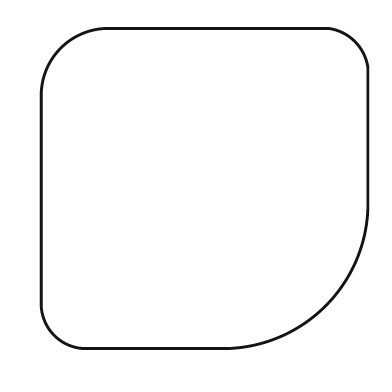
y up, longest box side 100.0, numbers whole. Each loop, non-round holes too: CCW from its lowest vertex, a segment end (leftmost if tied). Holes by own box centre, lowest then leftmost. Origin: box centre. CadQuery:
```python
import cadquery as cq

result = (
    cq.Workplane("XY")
    .moveTo(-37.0, -49.0)
    .lineTo(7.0, -49.0)
    .threePointArc((37.0, -36.0), (50.0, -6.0))
    .lineTo(50.0, 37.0)
    .threePointArc((46.0, 45.0), (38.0, 49.0))
    .lineTo(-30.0, 49.0)
    .threePointArc((-44.0, 43.0), (-50.0, 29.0))
    .lineTo(-50.0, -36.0)
    .threePointArc((-46.0, -45.0), (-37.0, -49.0))
    .close()
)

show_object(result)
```